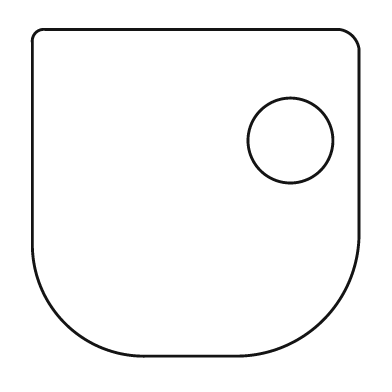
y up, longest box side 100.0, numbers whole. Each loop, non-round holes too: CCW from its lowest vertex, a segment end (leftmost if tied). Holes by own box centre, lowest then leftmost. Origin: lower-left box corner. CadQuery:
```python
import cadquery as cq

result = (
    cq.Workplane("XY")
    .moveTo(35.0, 0.0)
    .lineTo(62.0, 0.0)
    .threePointArc((89.0, 11.0), (100.0, 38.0))
    .lineTo(100.0, 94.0)
    .threePointArc((98.0, 98.0), (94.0, 100.0))
    .lineTo(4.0, 100.0)
    .threePointArc((1.0, 99.0), (0.0, 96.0))
    .lineTo(0.0, 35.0)
    .threePointArc((10.0, 10.0), (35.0, 0.0))
    .close()
    .moveTo(79.0, 66.0)
    .circle(13.0)
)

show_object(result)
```